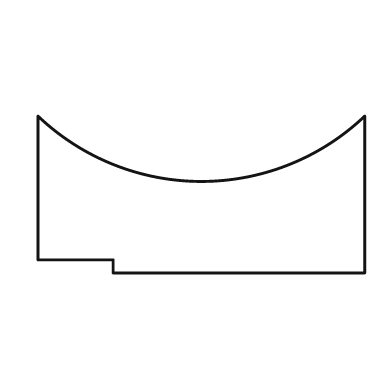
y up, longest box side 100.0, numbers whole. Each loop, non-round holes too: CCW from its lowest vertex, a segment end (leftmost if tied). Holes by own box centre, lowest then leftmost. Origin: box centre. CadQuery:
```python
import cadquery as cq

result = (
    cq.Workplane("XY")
    .moveTo(-27.0, -24.0)
    .lineTo(50.0, -24.0)
    .lineTo(50.0, 24.0)
    .threePointArc((0.0, 4.0), (-50.0, 24.0))
    .lineTo(-50.0, -20.0)
    .lineTo(-27.0, -20.0)
    .close()
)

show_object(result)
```